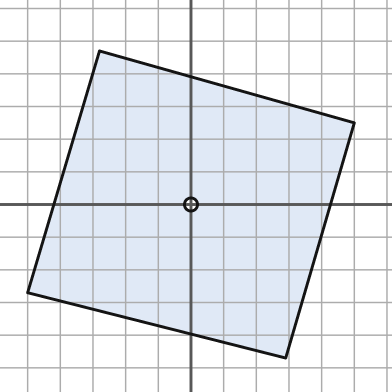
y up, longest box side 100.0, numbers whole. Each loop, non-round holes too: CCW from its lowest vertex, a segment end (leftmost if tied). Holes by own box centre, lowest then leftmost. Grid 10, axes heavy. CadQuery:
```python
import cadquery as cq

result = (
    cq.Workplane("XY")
    .moveTo(29.0, -47.0)
    .lineTo(50.0, 25.0)
    .lineTo(-28.0, 47.0)
    .lineTo(-50.0, -27.0)
    .close()
    .moveTo(0.0, 0.0)
    .circle(2.0)
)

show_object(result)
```